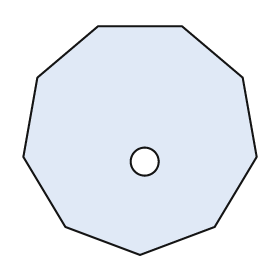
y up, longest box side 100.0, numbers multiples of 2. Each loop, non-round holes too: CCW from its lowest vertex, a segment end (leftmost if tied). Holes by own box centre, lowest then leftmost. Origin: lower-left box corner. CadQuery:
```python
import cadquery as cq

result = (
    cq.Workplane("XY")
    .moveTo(50.0, 0.0)
    .lineTo(82.0, 12.0)
    .lineTo(100.0, 42.0)
    .lineTo(94.0, 76.0)
    .lineTo(68.0, 98.0)
    .lineTo(32.0, 98.0)
    .lineTo(6.0, 76.0)
    .lineTo(0.0, 42.0)
    .lineTo(18.0, 12.0)
    .close()
    .moveTo(52.0, 40.0)
    .circle(6.0)
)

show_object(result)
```